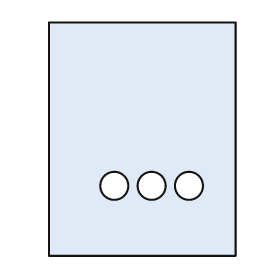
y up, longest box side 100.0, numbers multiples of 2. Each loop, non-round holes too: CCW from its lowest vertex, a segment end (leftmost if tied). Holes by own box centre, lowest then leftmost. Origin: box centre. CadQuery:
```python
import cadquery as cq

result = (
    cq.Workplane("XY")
    .moveTo(-40.0, -50.0)
    .lineTo(40.0, -50.0)
    .lineTo(40.0, 50.0)
    .lineTo(-40.0, 50.0)
    .close()
    .moveTo(-12.0, -20.0)
    .circle(6.0)
    .moveTo(4.0, -20.0)
    .circle(6.0)
    .moveTo(20.0, -20.0)
    .circle(6.0)
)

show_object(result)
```